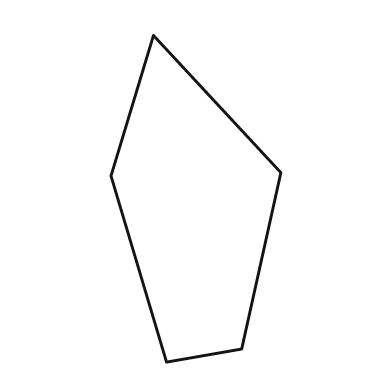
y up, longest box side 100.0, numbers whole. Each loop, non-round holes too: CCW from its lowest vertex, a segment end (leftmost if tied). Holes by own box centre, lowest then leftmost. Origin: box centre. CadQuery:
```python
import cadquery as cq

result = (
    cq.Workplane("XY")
    .moveTo(-9.0, -50.0)
    .lineTo(14.0, -46.0)
    .lineTo(26.0, 8.0)
    .lineTo(-13.0, 50.0)
    .lineTo(-26.0, 7.0)
    .close()
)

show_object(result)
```